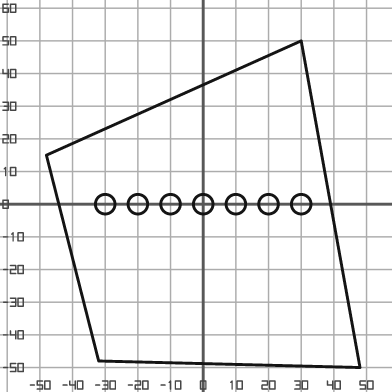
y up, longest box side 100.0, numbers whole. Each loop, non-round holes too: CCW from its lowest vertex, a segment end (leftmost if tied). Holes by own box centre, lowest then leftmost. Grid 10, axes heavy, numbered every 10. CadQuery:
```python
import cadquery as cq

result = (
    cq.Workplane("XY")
    .moveTo(48.0, -50.0)
    .lineTo(30.0, 50.0)
    .lineTo(-48.0, 15.0)
    .lineTo(-32.0, -48.0)
    .close()
    .moveTo(-30.0, 0.0)
    .circle(3.0)
    .moveTo(-20.0, 0.0)
    .circle(3.0)
    .moveTo(-10.0, 0.0)
    .circle(3.0)
    .moveTo(0.0, 0.0)
    .circle(3.0)
    .moveTo(10.0, 0.0)
    .circle(3.0)
    .moveTo(20.0, 0.0)
    .circle(3.0)
    .moveTo(30.0, 0.0)
    .circle(3.0)
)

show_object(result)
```